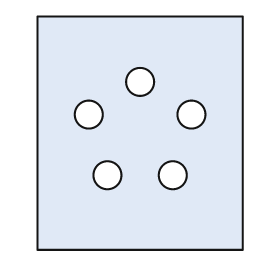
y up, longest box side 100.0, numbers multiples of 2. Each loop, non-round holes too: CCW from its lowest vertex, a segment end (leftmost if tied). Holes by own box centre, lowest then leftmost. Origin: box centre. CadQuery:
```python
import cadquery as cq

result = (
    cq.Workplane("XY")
    .moveTo(-44.0, -50.0)
    .lineTo(44.0, -50.0)
    .lineTo(44.0, 50.0)
    .lineTo(-44.0, 50.0)
    .close()
    .moveTo(-14.0, -18.0)
    .circle(6.0)
    .moveTo(14.0, -18.0)
    .circle(6.0)
    .moveTo(-22.0, 8.0)
    .circle(6.0)
    .moveTo(22.0, 8.0)
    .circle(6.0)
    .moveTo(0.0, 22.0)
    .circle(6.0)
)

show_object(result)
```